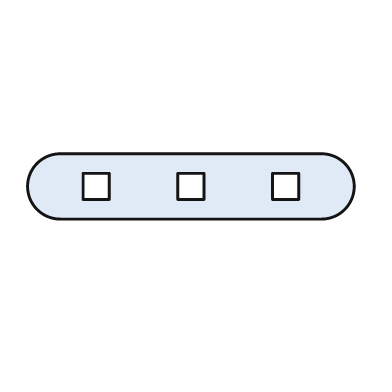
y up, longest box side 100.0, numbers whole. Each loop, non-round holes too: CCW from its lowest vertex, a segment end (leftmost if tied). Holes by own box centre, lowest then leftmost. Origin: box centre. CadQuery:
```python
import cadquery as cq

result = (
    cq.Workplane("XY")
    .moveTo(-40.0, -10.0)
    .lineTo(40.0, -10.0)
    .threePointArc((50.0, 0.0), (40.0, 10.0))
    .lineTo(-40.0, 10.0)
    .threePointArc((-50.0, 0.0), (-40.0, -10.0))
    .close()
    .moveTo(-33.0, -4.0)
    .lineTo(-25.0, -4.0)
    .lineTo(-25.0, 4.0)
    .lineTo(-33.0, 4.0)
    .close()
    .moveTo(-4.0, -4.0)
    .lineTo(4.0, -4.0)
    .lineTo(4.0, 4.0)
    .lineTo(-4.0, 4.0)
    .close()
    .moveTo(25.0, -4.0)
    .lineTo(33.0, -4.0)
    .lineTo(33.0, 4.0)
    .lineTo(25.0, 4.0)
    .close()
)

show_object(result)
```